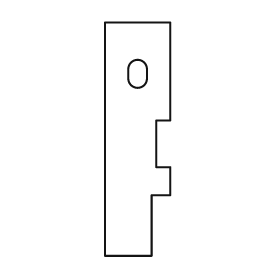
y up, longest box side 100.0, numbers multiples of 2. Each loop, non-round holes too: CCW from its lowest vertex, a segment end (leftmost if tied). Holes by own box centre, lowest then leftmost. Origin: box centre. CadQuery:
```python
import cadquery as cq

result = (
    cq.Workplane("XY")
    .moveTo(-14.0, -50.0)
    .lineTo(6.0, -50.0)
    .lineTo(6.0, -24.0)
    .lineTo(14.0, -24.0)
    .lineTo(14.0, -12.0)
    .lineTo(8.0, -12.0)
    .lineTo(8.0, 8.0)
    .lineTo(14.0, 8.0)
    .lineTo(14.0, 50.0)
    .lineTo(-14.0, 50.0)
    .close()
    .moveTo(-4.0, 26.0)
    .threePointArc((0.0, 22.0), (4.0, 26.0))
    .lineTo(4.0, 30.0)
    .threePointArc((0.0, 34.0), (-4.0, 30.0))
    .close()
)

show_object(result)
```